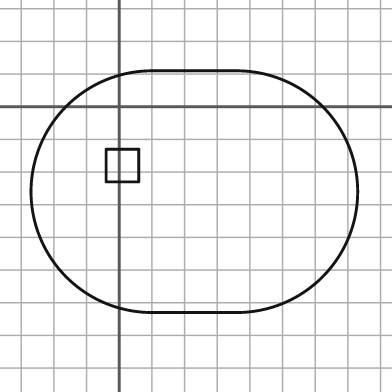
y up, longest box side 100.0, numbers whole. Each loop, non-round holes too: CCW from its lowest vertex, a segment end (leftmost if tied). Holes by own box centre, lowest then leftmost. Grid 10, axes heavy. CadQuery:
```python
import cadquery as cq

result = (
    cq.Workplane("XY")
    .moveTo(10.0, -63.0)
    .lineTo(36.0, -63.0)
    .threePointArc((73.0, -26.0), (36.0, 11.0))
    .lineTo(10.0, 11.0)
    .threePointArc((-27.0, -26.0), (10.0, -63.0))
    .close()
    .moveTo(-4.0, -23.0)
    .lineTo(6.0, -23.0)
    .lineTo(6.0, -13.0)
    .lineTo(-4.0, -13.0)
    .close()
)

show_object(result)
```